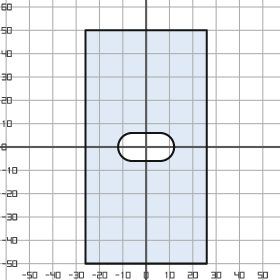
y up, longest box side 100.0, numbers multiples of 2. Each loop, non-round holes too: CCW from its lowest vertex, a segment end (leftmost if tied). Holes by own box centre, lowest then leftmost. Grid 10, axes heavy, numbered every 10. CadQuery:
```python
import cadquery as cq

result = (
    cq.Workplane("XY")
    .moveTo(-26.0, -50.0)
    .lineTo(26.0, -50.0)
    .lineTo(26.0, 50.0)
    .lineTo(-26.0, 50.0)
    .close()
    .moveTo(-6.0, -6.0)
    .lineTo(6.0, -6.0)
    .threePointArc((12.0, 0.0), (6.0, 6.0))
    .lineTo(-6.0, 6.0)
    .threePointArc((-12.0, 0.0), (-6.0, -6.0))
    .close()
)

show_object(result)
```